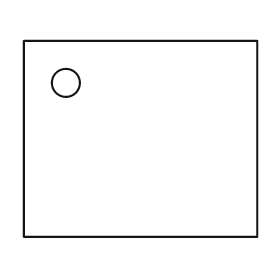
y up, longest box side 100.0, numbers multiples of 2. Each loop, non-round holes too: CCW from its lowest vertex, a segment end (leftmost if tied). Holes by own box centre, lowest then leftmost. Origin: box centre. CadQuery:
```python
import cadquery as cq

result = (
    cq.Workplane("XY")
    .moveTo(-50.0, -42.0)
    .lineTo(50.0, -42.0)
    .lineTo(50.0, 42.0)
    .lineTo(-50.0, 42.0)
    .close()
    .moveTo(-32.0, 24.0)
    .circle(6.0)
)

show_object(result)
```